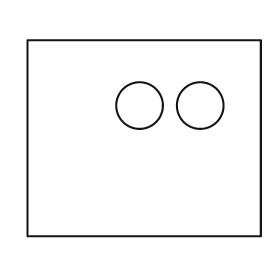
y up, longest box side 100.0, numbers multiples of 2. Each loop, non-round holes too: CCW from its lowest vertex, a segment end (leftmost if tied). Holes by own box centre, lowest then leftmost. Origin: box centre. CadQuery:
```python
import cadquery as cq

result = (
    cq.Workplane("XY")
    .moveTo(-50.0, -42.0)
    .lineTo(50.0, -42.0)
    .lineTo(50.0, 42.0)
    .lineTo(-50.0, 42.0)
    .close()
    .moveTo(-2.0, 14.0)
    .circle(10.0)
    .moveTo(24.0, 14.0)
    .circle(10.0)
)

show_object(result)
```